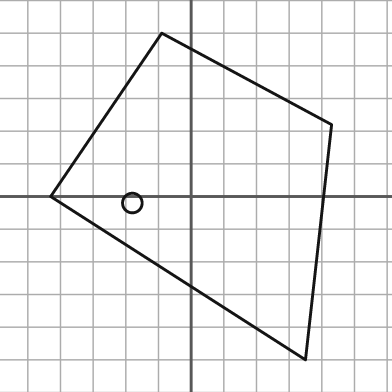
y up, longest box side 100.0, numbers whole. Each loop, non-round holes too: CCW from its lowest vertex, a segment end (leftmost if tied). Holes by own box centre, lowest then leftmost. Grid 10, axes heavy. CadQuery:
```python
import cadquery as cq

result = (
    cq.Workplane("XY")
    .moveTo(35.0, -50.0)
    .lineTo(43.0, 22.0)
    .lineTo(-9.0, 50.0)
    .lineTo(-43.0, 0.0)
    .close()
    .moveTo(-18.0, -2.0)
    .circle(3.0)
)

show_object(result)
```